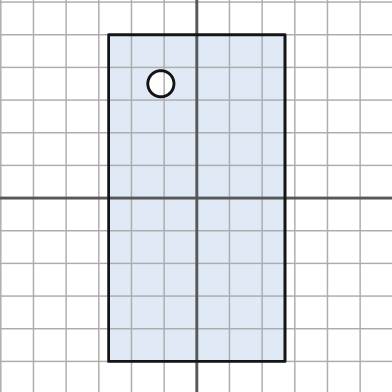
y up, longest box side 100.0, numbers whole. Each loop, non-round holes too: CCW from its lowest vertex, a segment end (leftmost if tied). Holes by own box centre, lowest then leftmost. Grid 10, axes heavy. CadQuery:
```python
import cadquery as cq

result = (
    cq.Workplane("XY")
    .moveTo(-27.0, -50.0)
    .lineTo(27.0, -50.0)
    .lineTo(27.0, 50.0)
    .lineTo(-27.0, 50.0)
    .close()
    .moveTo(-11.0, 35.0)
    .circle(4.0)
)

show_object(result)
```